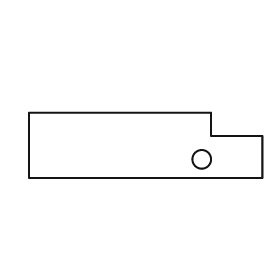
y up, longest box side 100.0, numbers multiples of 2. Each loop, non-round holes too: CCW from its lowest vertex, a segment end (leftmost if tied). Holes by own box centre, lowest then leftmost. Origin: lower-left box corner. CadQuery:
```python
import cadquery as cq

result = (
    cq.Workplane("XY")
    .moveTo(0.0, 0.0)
    .lineTo(100.0, 0.0)
    .lineTo(100.0, 18.0)
    .lineTo(78.0, 18.0)
    .lineTo(78.0, 28.0)
    .lineTo(0.0, 28.0)
    .close()
    .moveTo(74.0, 8.0)
    .circle(4.0)
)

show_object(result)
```